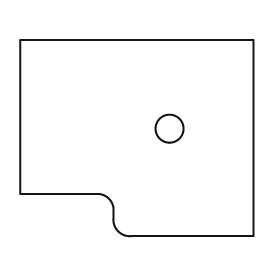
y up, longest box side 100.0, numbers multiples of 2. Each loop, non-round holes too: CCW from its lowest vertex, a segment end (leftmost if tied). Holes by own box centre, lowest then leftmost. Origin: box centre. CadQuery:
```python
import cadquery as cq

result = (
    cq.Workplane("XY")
    .moveTo(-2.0, -42.0)
    .lineTo(50.0, -42.0)
    .lineTo(50.0, 42.0)
    .lineTo(-50.0, 42.0)
    .lineTo(-50.0, -24.0)
    .lineTo(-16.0, -24.0)
    .threePointArc((-12.0, -26.0), (-10.0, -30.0))
    .lineTo(-10.0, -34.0)
    .threePointArc((-8.0, -40.0), (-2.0, -42.0))
    .close()
    .moveTo(14.0, 4.0)
    .circle(6.0)
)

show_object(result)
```